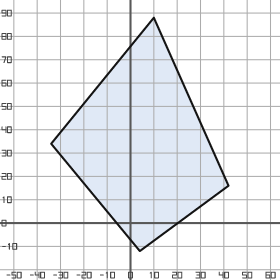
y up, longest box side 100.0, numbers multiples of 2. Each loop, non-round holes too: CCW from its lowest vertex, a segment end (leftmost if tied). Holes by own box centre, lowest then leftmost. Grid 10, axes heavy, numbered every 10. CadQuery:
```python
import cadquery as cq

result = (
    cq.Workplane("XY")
    .moveTo(4.0, -12.0)
    .lineTo(42.0, 16.0)
    .lineTo(10.0, 88.0)
    .lineTo(-34.0, 34.0)
    .close()
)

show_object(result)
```